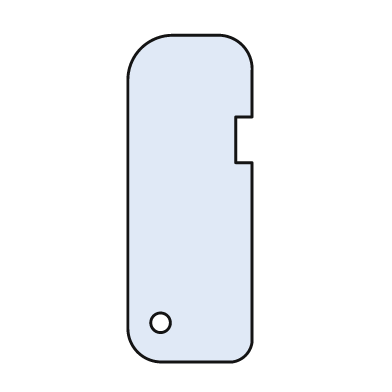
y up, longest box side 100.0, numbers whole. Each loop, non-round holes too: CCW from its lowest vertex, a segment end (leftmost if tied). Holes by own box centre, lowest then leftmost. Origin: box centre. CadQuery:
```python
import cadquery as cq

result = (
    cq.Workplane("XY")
    .moveTo(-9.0, -50.0)
    .lineTo(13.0, -50.0)
    .threePointArc((17.0, -48.0), (19.0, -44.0))
    .lineTo(19.0, 11.0)
    .lineTo(14.0, 11.0)
    .lineTo(14.0, 25.0)
    .lineTo(19.0, 25.0)
    .lineTo(19.0, 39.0)
    .threePointArc((16.0, 47.0), (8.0, 50.0))
    .lineTo(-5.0, 50.0)
    .threePointArc((-15.0, 46.0), (-19.0, 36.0))
    .lineTo(-19.0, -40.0)
    .threePointArc((-16.0, -47.0), (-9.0, -50.0))
    .close()
    .moveTo(-9.0, -38.0)
    .circle(3.0)
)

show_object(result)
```